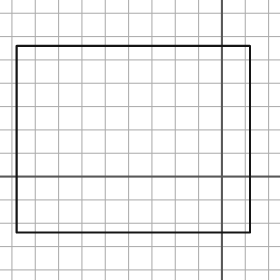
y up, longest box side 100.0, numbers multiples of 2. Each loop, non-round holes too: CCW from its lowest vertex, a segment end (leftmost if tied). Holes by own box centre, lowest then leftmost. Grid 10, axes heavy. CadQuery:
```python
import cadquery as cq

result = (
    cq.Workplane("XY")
    .moveTo(-88.0, -24.0)
    .lineTo(12.0, -24.0)
    .lineTo(12.0, 56.0)
    .lineTo(-88.0, 56.0)
    .close()
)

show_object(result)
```